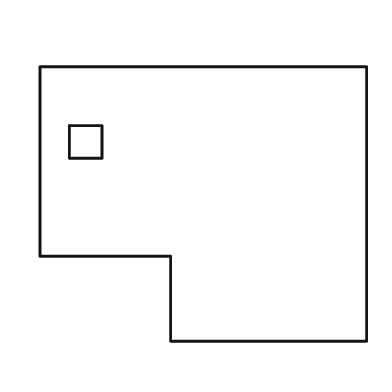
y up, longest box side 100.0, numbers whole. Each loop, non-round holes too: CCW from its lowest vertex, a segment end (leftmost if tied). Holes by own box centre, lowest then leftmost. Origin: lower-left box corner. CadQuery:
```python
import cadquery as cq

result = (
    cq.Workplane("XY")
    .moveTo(40.0, 0.0)
    .lineTo(100.0, 0.0)
    .lineTo(100.0, 84.0)
    .lineTo(0.0, 84.0)
    .lineTo(0.0, 26.0)
    .lineTo(40.0, 26.0)
    .close()
    .moveTo(9.0, 56.0)
    .lineTo(19.0, 56.0)
    .lineTo(19.0, 66.0)
    .lineTo(9.0, 66.0)
    .close()
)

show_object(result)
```